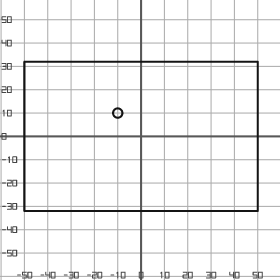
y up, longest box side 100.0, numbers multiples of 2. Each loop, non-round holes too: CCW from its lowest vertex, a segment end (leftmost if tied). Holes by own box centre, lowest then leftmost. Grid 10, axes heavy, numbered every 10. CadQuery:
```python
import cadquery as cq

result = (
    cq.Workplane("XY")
    .moveTo(-50.0, -32.0)
    .lineTo(50.0, -32.0)
    .lineTo(50.0, 32.0)
    .lineTo(-50.0, 32.0)
    .close()
    .moveTo(-10.0, 10.0)
    .circle(2.0)
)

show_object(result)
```